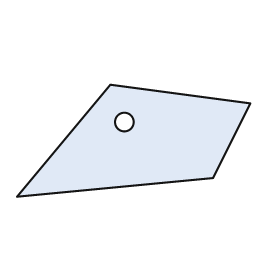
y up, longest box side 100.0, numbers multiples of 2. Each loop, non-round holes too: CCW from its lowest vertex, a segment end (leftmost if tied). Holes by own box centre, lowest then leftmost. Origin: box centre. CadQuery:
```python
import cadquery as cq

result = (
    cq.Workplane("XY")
    .moveTo(-50.0, -24.0)
    .lineTo(34.0, -16.0)
    .lineTo(50.0, 16.0)
    .lineTo(-10.0, 24.0)
    .close()
    .moveTo(-4.0, 8.0)
    .circle(4.0)
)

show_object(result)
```